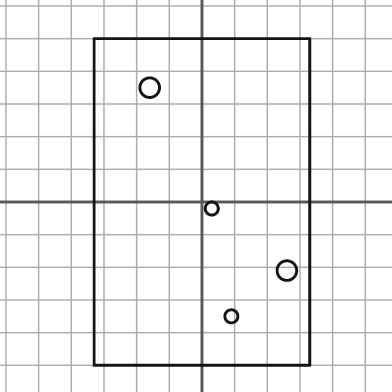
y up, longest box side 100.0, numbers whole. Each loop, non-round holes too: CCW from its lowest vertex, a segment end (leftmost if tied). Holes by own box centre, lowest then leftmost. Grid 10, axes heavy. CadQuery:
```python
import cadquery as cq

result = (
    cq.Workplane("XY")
    .moveTo(-33.0, -50.0)
    .lineTo(33.0, -50.0)
    .lineTo(33.0, 50.0)
    .lineTo(-33.0, 50.0)
    .close()
    .moveTo(9.0, -35.0)
    .circle(2.0)
    .moveTo(26.0, -21.0)
    .circle(3.0)
    .moveTo(3.0, -2.0)
    .circle(2.0)
    .moveTo(-16.0, 35.0)
    .circle(3.0)
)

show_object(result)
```